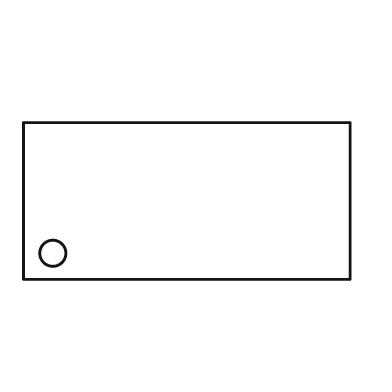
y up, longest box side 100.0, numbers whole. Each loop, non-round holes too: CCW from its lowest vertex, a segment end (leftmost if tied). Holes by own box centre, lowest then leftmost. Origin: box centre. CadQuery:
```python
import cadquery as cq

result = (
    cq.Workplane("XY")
    .moveTo(-50.0, -24.0)
    .lineTo(50.0, -24.0)
    .lineTo(50.0, 24.0)
    .lineTo(-50.0, 24.0)
    .close()
    .moveTo(-41.0, -16.0)
    .circle(4.0)
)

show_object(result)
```